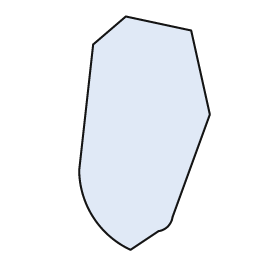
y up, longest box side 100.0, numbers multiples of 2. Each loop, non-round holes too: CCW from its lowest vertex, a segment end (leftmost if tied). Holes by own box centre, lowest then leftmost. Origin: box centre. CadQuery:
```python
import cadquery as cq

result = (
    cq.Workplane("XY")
    .moveTo(-6.0, -50.0)
    .lineTo(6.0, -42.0)
    .threePointArc((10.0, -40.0), (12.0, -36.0))
    .lineTo(28.0, 8.0)
    .lineTo(20.0, 44.0)
    .lineTo(-8.0, 50.0)
    .lineTo(-22.0, 38.0)
    .lineTo(-28.0, -16.0)
    .threePointArc((-22.0, -36.0), (-6.0, -50.0))
    .close()
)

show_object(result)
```